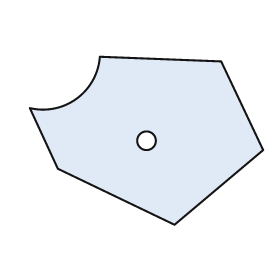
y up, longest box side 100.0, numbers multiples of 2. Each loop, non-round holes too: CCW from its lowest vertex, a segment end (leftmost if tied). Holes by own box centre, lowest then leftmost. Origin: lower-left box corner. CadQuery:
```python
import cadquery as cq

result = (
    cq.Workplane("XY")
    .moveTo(62.0, 0.0)
    .lineTo(100.0, 32.0)
    .lineTo(82.0, 70.0)
    .lineTo(30.0, 72.0)
    .threePointArc((20.0, 54.0), (0.0, 50.0))
    .lineTo(12.0, 24.0)
    .close()
    .moveTo(50.0, 36.0)
    .circle(4.0)
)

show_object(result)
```